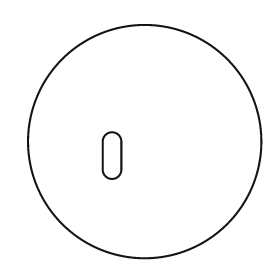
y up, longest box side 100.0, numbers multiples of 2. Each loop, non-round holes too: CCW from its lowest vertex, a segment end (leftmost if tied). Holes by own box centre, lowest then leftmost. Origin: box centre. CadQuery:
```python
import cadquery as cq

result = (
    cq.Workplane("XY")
    .moveTo(0.0, 0.0)
    .circle(50.0)
    .moveTo(-18.0, -12.0)
    .threePointArc((-14.0, -16.0), (-10.0, -12.0))
    .lineTo(-10.0, 0.0)
    .threePointArc((-14.0, 4.0), (-18.0, 0.0))
    .close()
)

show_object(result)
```